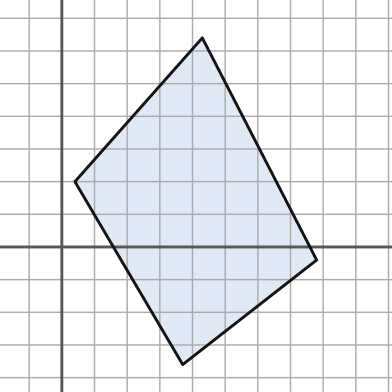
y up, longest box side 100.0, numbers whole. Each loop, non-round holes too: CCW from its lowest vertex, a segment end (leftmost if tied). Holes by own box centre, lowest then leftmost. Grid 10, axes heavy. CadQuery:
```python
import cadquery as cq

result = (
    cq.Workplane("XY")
    .moveTo(37.0, -36.0)
    .lineTo(78.0, -4.0)
    .lineTo(43.0, 64.0)
    .lineTo(4.0, 20.0)
    .close()
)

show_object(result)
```